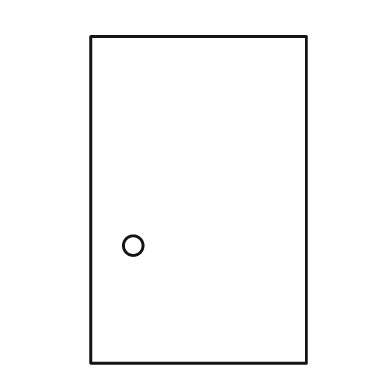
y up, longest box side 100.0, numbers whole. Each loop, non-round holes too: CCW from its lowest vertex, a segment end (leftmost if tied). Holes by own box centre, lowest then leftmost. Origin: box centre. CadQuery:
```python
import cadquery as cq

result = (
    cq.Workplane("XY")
    .moveTo(-33.0, -50.0)
    .lineTo(33.0, -50.0)
    .lineTo(33.0, 50.0)
    .lineTo(-33.0, 50.0)
    .close()
    .moveTo(-20.0, -14.0)
    .circle(3.0)
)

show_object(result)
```